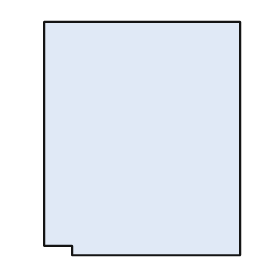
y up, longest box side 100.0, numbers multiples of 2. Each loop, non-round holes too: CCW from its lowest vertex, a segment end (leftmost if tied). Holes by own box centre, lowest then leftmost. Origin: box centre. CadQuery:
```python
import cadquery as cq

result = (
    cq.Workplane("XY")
    .moveTo(-30.0, -50.0)
    .lineTo(42.0, -50.0)
    .lineTo(42.0, 50.0)
    .lineTo(-42.0, 50.0)
    .lineTo(-42.0, -46.0)
    .lineTo(-30.0, -46.0)
    .close()
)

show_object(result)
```